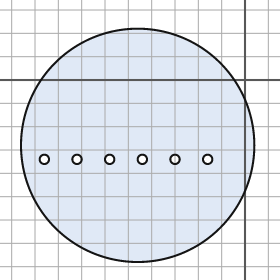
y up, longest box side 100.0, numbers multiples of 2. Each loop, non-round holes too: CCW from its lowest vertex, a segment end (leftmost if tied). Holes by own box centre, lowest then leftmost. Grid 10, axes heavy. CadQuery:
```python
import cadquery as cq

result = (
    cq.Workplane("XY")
    .moveTo(-46.0, -28.0)
    .circle(50.0)
    .moveTo(-86.0, -34.0)
    .circle(2.0)
    .moveTo(-72.0, -34.0)
    .circle(2.0)
    .moveTo(-58.0, -34.0)
    .circle(2.0)
    .moveTo(-44.0, -34.0)
    .circle(2.0)
    .moveTo(-30.0, -34.0)
    .circle(2.0)
    .moveTo(-16.0, -34.0)
    .circle(2.0)
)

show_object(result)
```